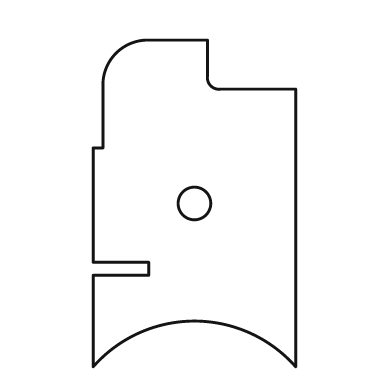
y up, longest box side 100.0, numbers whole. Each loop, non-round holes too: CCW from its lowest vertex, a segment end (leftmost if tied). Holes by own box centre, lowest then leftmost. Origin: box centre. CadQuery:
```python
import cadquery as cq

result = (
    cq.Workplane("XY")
    .moveTo(-31.0, -50.0)
    .threePointArc((0.0, -36.0), (31.0, -50.0))
    .lineTo(31.0, 35.0)
    .lineTo(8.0, 35.0)
    .threePointArc((5.0, 36.0), (4.0, 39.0))
    .lineTo(4.0, 50.0)
    .lineTo(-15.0, 50.0)
    .threePointArc((-24.0, 46.0), (-28.0, 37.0))
    .lineTo(-28.0, 17.0)
    .lineTo(-31.0, 17.0)
    .lineTo(-31.0, -18.0)
    .lineTo(-14.0, -18.0)
    .lineTo(-14.0, -22.0)
    .lineTo(-31.0, -22.0)
    .close()
    .moveTo(0.0, 0.0)
    .circle(5.0)
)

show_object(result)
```